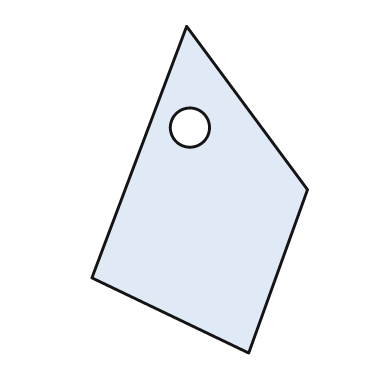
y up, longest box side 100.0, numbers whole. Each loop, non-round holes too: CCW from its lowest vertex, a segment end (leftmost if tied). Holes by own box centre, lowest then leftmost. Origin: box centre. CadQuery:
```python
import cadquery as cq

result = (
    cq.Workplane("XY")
    .moveTo(15.0, -50.0)
    .lineTo(33.0, 0.0)
    .lineTo(-4.0, 50.0)
    .lineTo(-33.0, -27.0)
    .close()
    .moveTo(-3.0, 19.0)
    .circle(6.0)
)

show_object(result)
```